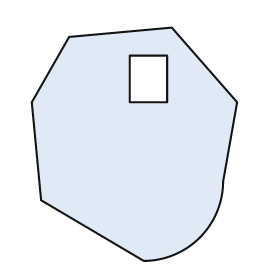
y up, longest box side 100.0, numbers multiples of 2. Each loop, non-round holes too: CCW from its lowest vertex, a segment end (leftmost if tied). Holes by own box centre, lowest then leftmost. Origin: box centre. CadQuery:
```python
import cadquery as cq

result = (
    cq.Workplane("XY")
    .moveTo(4.0, -50.0)
    .threePointArc((28.0, -40.0), (38.0, -16.0))
    .lineTo(44.0, 18.0)
    .lineTo(16.0, 50.0)
    .lineTo(-28.0, 46.0)
    .lineTo(-44.0, 18.0)
    .lineTo(-40.0, -24.0)
    .close()
    .moveTo(-2.0, 18.0)
    .lineTo(14.0, 18.0)
    .lineTo(14.0, 38.0)
    .lineTo(-2.0, 38.0)
    .close()
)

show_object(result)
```